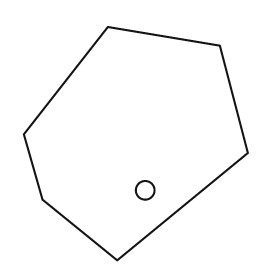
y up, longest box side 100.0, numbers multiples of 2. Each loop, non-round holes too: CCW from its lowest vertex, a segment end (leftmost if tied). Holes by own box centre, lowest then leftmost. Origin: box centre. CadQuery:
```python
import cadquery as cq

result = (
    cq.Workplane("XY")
    .moveTo(-8.0, -50.0)
    .lineTo(48.0, -4.0)
    .lineTo(36.0, 42.0)
    .lineTo(-12.0, 50.0)
    .lineTo(-48.0, 4.0)
    .lineTo(-40.0, -24.0)
    .close()
    .moveTo(4.0, -20.0)
    .circle(4.0)
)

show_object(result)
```